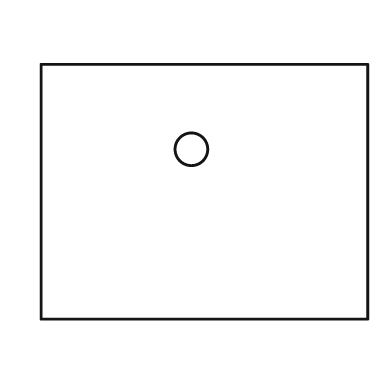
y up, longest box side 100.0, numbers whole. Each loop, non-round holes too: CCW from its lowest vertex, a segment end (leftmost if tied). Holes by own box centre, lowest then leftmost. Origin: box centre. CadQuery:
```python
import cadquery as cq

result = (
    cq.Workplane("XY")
    .moveTo(-50.0, -39.0)
    .lineTo(50.0, -39.0)
    .lineTo(50.0, 39.0)
    .lineTo(-50.0, 39.0)
    .close()
    .moveTo(-4.0, 13.0)
    .circle(5.0)
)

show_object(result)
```